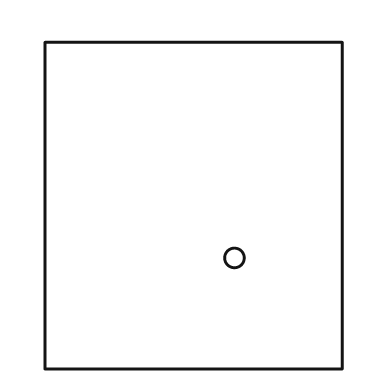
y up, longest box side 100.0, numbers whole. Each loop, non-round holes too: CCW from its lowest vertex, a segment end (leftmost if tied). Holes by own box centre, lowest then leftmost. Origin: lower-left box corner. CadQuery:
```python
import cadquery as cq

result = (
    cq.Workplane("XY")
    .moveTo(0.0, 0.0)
    .lineTo(91.0, 0.0)
    .lineTo(91.0, 100.0)
    .lineTo(0.0, 100.0)
    .close()
    .moveTo(58.0, 34.0)
    .circle(3.0)
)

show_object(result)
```